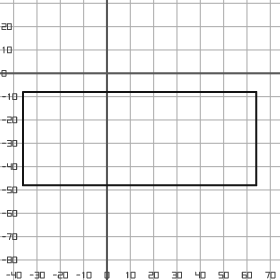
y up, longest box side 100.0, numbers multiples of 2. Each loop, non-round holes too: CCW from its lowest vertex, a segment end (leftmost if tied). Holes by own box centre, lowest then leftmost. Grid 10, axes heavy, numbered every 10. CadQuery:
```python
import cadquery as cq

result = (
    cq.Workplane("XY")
    .moveTo(-36.0, -48.0)
    .lineTo(64.0, -48.0)
    .lineTo(64.0, -8.0)
    .lineTo(-36.0, -8.0)
    .close()
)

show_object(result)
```